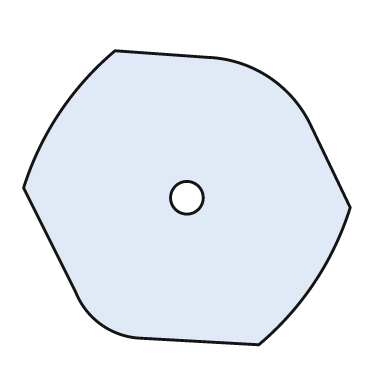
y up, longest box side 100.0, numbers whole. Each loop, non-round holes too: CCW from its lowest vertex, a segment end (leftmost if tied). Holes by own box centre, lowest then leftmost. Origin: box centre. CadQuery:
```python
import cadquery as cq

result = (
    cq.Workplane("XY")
    .moveTo(22.0, -45.0)
    .threePointArc((39.0, -26.0), (50.0, -3.0))
    .lineTo(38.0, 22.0)
    .threePointArc((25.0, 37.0), (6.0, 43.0))
    .lineTo(-22.0, 45.0)
    .threePointArc((-39.0, 26.0), (-50.0, 3.0))
    .lineTo(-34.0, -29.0)
    .threePointArc((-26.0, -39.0), (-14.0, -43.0))
    .close()
    .moveTo(0.0, 0.0)
    .circle(5.0)
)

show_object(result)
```